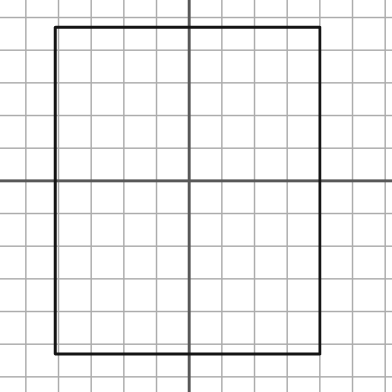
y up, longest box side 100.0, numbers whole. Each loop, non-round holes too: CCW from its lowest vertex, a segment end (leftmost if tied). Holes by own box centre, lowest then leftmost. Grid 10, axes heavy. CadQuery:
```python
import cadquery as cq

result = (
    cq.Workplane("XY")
    .moveTo(-41.0, -53.0)
    .lineTo(40.0, -53.0)
    .lineTo(40.0, 47.0)
    .lineTo(-41.0, 47.0)
    .close()
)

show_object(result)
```